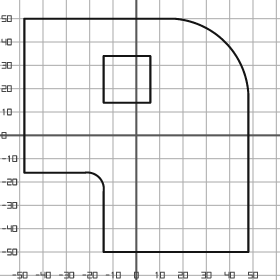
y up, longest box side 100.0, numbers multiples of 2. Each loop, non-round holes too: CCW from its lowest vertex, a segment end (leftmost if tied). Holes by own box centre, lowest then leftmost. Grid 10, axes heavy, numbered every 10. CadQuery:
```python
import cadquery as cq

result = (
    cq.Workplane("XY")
    .moveTo(-14.0, -50.0)
    .lineTo(48.0, -50.0)
    .lineTo(48.0, 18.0)
    .threePointArc((38.0, 40.0), (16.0, 50.0))
    .lineTo(-48.0, 50.0)
    .lineTo(-48.0, -16.0)
    .lineTo(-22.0, -16.0)
    .threePointArc((-16.0, -18.0), (-14.0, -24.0))
    .close()
    .moveTo(-14.0, 14.0)
    .lineTo(6.0, 14.0)
    .lineTo(6.0, 34.0)
    .lineTo(-14.0, 34.0)
    .close()
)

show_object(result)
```